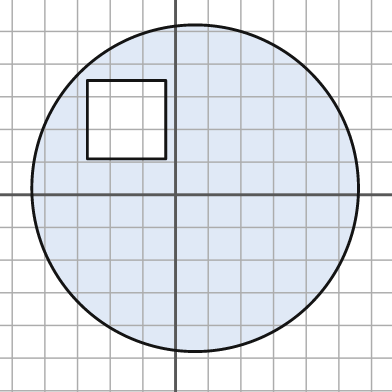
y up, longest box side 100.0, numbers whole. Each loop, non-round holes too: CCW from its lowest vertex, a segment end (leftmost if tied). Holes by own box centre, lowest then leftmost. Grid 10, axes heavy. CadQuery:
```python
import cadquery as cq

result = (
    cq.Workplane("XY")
    .moveTo(6.0, 2.0)
    .circle(50.0)
    .moveTo(-27.0, 11.0)
    .lineTo(-3.0, 11.0)
    .lineTo(-3.0, 35.0)
    .lineTo(-27.0, 35.0)
    .close()
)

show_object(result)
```